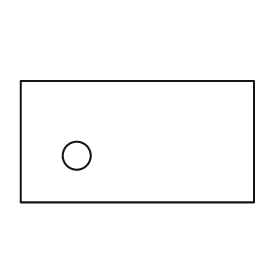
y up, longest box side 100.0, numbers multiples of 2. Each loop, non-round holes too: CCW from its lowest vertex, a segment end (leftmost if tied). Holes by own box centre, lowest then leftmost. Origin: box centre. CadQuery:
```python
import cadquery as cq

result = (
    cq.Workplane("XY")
    .moveTo(-50.0, -26.0)
    .lineTo(50.0, -26.0)
    .lineTo(50.0, 26.0)
    .lineTo(-50.0, 26.0)
    .close()
    .moveTo(-26.0, -6.0)
    .circle(6.0)
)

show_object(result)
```